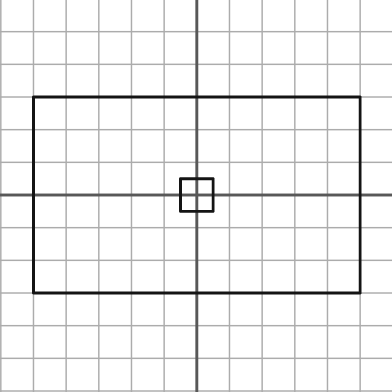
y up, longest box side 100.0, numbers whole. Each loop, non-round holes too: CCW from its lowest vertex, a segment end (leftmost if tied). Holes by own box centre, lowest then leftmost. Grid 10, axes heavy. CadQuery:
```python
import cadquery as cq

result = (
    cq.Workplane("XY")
    .moveTo(-50.0, -30.0)
    .lineTo(50.0, -30.0)
    .lineTo(50.0, 30.0)
    .lineTo(-50.0, 30.0)
    .close()
    .moveTo(-5.0, -5.0)
    .lineTo(5.0, -5.0)
    .lineTo(5.0, 5.0)
    .lineTo(-5.0, 5.0)
    .close()
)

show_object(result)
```